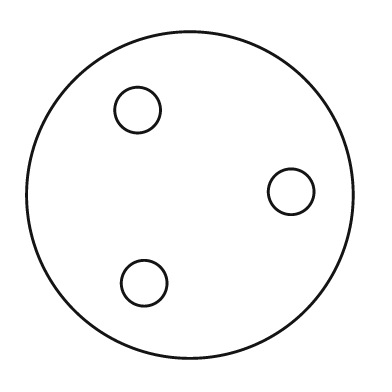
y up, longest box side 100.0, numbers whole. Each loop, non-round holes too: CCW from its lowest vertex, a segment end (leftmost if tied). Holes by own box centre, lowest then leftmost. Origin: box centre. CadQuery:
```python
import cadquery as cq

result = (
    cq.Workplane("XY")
    .moveTo(0.0, 0.0)
    .circle(50.0)
    .moveTo(-14.0, -27.0)
    .circle(7.0)
    .moveTo(31.0, 1.0)
    .circle(7.0)
    .moveTo(-16.0, 26.0)
    .circle(7.0)
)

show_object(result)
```